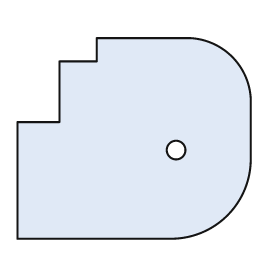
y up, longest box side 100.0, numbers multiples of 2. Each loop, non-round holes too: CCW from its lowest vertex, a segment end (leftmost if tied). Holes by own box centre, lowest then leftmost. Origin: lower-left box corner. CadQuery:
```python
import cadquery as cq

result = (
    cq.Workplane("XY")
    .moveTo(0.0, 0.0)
    .lineTo(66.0, 0.0)
    .threePointArc((90.0, 10.0), (100.0, 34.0))
    .lineTo(100.0, 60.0)
    .threePointArc((92.0, 78.0), (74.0, 86.0))
    .lineTo(34.0, 86.0)
    .lineTo(34.0, 76.0)
    .lineTo(18.0, 76.0)
    .lineTo(18.0, 50.0)
    .lineTo(0.0, 50.0)
    .close()
    .moveTo(68.0, 38.0)
    .circle(4.0)
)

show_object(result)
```